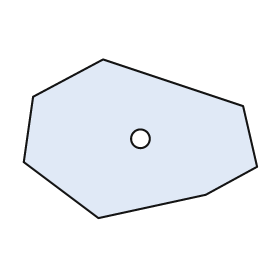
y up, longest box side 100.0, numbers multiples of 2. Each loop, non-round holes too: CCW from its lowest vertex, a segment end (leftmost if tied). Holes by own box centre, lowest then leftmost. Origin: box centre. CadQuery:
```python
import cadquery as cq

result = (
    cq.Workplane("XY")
    .moveTo(-18.0, -34.0)
    .lineTo(28.0, -24.0)
    .lineTo(50.0, -12.0)
    .lineTo(44.0, 14.0)
    .lineTo(-16.0, 34.0)
    .lineTo(-46.0, 18.0)
    .lineTo(-50.0, -10.0)
    .close()
    .moveTo(0.0, 0.0)
    .circle(4.0)
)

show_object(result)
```